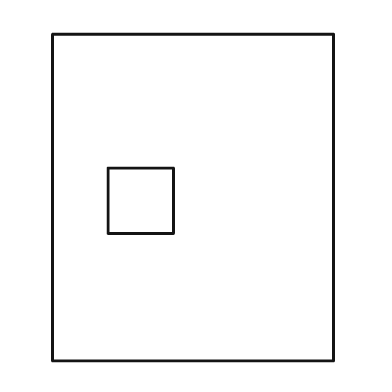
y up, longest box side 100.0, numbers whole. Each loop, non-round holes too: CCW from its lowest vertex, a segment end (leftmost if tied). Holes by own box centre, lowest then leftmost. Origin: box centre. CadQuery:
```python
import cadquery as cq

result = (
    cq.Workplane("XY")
    .moveTo(-43.0, -50.0)
    .lineTo(43.0, -50.0)
    .lineTo(43.0, 50.0)
    .lineTo(-43.0, 50.0)
    .close()
    .moveTo(-26.0, -11.0)
    .lineTo(-6.0, -11.0)
    .lineTo(-6.0, 9.0)
    .lineTo(-26.0, 9.0)
    .close()
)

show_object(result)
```